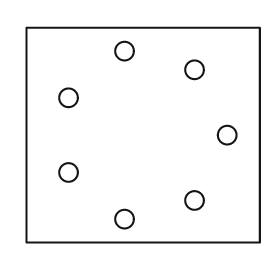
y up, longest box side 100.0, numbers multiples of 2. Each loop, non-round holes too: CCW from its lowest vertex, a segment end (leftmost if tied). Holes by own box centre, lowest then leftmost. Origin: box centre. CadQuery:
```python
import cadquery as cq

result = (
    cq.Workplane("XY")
    .moveTo(-50.0, -46.0)
    .lineTo(50.0, -46.0)
    .lineTo(50.0, 46.0)
    .lineTo(-50.0, 46.0)
    .close()
    .moveTo(-8.0, -36.0)
    .circle(4.0)
    .moveTo(22.0, -28.0)
    .circle(4.0)
    .moveTo(-32.0, -16.0)
    .circle(4.0)
    .moveTo(36.0, 0.0)
    .circle(4.0)
    .moveTo(-32.0, 16.0)
    .circle(4.0)
    .moveTo(22.0, 28.0)
    .circle(4.0)
    .moveTo(-8.0, 36.0)
    .circle(4.0)
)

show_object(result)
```